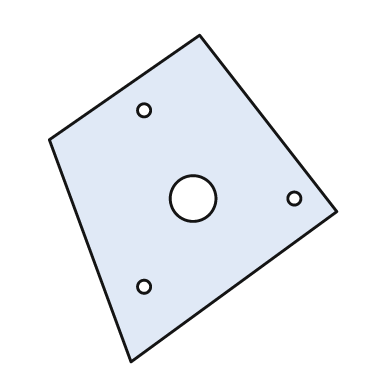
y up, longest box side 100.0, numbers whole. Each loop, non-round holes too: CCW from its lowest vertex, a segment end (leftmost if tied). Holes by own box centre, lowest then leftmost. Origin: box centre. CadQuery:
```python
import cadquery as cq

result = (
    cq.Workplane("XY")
    .moveTo(-19.0, -50.0)
    .lineTo(44.0, -4.0)
    .lineTo(2.0, 50.0)
    .lineTo(-44.0, 18.0)
    .close()
    .moveTo(-15.0, -27.0)
    .circle(2.0)
    .moveTo(0.0, 0.0)
    .circle(7.0)
    .moveTo(31.0, 0.0)
    .circle(2.0)
    .moveTo(-15.0, 27.0)
    .circle(2.0)
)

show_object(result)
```